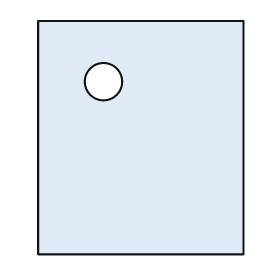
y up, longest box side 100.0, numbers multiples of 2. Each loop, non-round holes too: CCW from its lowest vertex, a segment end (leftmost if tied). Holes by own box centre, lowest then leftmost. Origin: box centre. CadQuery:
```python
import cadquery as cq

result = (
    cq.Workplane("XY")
    .moveTo(-44.0, -50.0)
    .lineTo(44.0, -50.0)
    .lineTo(44.0, 50.0)
    .lineTo(-44.0, 50.0)
    .close()
    .moveTo(-16.0, 24.0)
    .circle(8.0)
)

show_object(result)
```